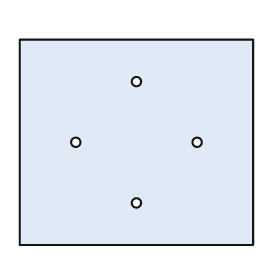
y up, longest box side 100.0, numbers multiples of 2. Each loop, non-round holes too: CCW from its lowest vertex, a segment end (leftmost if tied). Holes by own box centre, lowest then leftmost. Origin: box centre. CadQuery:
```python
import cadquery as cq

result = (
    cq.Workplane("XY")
    .moveTo(-50.0, -44.0)
    .lineTo(50.0, -44.0)
    .lineTo(50.0, 44.0)
    .lineTo(-50.0, 44.0)
    .close()
    .moveTo(0.0, -26.0)
    .circle(2.0)
    .moveTo(-26.0, 0.0)
    .circle(2.0)
    .moveTo(26.0, 0.0)
    .circle(2.0)
    .moveTo(0.0, 26.0)
    .circle(2.0)
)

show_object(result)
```